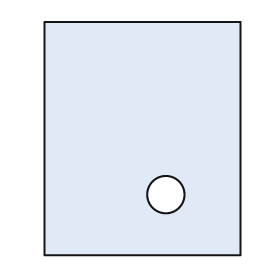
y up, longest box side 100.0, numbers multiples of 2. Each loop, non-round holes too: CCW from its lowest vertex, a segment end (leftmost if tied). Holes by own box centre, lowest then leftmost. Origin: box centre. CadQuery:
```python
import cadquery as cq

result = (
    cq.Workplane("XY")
    .moveTo(-42.0, -50.0)
    .lineTo(42.0, -50.0)
    .lineTo(42.0, 50.0)
    .lineTo(-42.0, 50.0)
    .close()
    .moveTo(10.0, -24.0)
    .circle(8.0)
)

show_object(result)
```